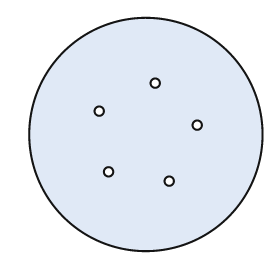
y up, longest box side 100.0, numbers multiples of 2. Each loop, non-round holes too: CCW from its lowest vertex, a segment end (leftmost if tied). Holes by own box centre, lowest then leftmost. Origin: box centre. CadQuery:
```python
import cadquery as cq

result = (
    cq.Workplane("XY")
    .moveTo(0.0, 0.0)
    .circle(50.0)
    .moveTo(10.0, -20.0)
    .circle(2.0)
    .moveTo(-16.0, -16.0)
    .circle(2.0)
    .moveTo(22.0, 4.0)
    .circle(2.0)
    .moveTo(-20.0, 10.0)
    .circle(2.0)
    .moveTo(4.0, 22.0)
    .circle(2.0)
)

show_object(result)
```